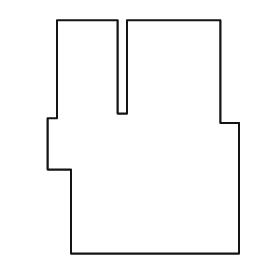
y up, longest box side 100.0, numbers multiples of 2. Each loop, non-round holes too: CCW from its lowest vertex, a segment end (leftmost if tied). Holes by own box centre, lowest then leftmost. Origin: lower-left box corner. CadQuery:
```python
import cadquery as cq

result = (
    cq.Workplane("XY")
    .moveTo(10.0, 0.0)
    .lineTo(82.0, 0.0)
    .lineTo(82.0, 56.0)
    .lineTo(74.0, 56.0)
    .lineTo(74.0, 100.0)
    .lineTo(34.0, 100.0)
    .lineTo(34.0, 60.0)
    .lineTo(30.0, 60.0)
    .lineTo(30.0, 100.0)
    .lineTo(4.0, 100.0)
    .lineTo(4.0, 58.0)
    .lineTo(0.0, 58.0)
    .lineTo(0.0, 36.0)
    .lineTo(10.0, 36.0)
    .close()
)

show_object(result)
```